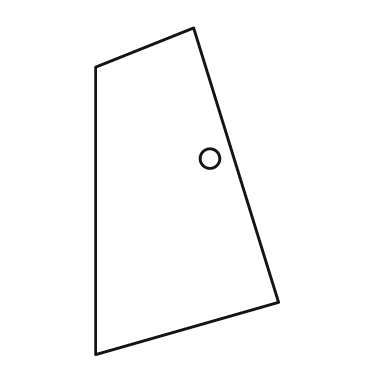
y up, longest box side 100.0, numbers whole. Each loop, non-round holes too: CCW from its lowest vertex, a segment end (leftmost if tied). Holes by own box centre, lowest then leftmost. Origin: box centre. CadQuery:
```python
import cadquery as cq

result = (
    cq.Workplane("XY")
    .moveTo(-28.0, -50.0)
    .lineTo(28.0, -34.0)
    .lineTo(2.0, 50.0)
    .lineTo(-28.0, 38.0)
    .close()
    .moveTo(7.0, 10.0)
    .circle(3.0)
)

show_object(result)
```